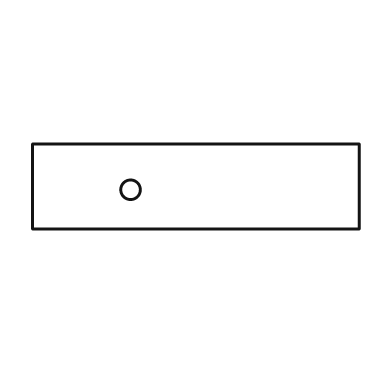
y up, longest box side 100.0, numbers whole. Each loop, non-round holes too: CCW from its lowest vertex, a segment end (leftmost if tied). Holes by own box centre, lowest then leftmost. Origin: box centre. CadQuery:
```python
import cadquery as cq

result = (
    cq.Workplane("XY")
    .moveTo(-50.0, -13.0)
    .lineTo(50.0, -13.0)
    .lineTo(50.0, 13.0)
    .lineTo(-50.0, 13.0)
    .close()
    .moveTo(-20.0, -1.0)
    .circle(3.0)
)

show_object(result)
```